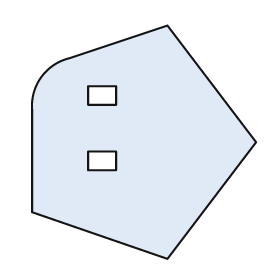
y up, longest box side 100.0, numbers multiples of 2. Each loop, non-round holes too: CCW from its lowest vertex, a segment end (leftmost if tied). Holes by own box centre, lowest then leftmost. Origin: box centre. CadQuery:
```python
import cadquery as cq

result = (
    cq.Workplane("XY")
    .moveTo(10.0, -50.0)
    .lineTo(48.0, 0.0)
    .lineTo(10.0, 50.0)
    .lineTo(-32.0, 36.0)
    .threePointArc((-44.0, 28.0), (-48.0, 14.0))
    .lineTo(-48.0, -30.0)
    .close()
    .moveTo(-24.0, -12.0)
    .lineTo(-12.0, -12.0)
    .lineTo(-12.0, -4.0)
    .lineTo(-24.0, -4.0)
    .close()
    .moveTo(-24.0, 16.0)
    .lineTo(-12.0, 16.0)
    .lineTo(-12.0, 24.0)
    .lineTo(-24.0, 24.0)
    .close()
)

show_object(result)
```